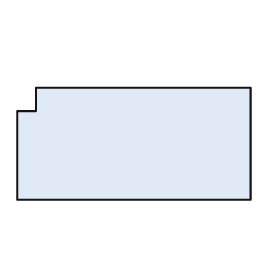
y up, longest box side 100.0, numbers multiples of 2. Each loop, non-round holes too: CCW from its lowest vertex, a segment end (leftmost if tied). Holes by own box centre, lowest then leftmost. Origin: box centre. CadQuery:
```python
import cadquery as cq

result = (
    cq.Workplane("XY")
    .moveTo(-50.0, -24.0)
    .lineTo(50.0, -24.0)
    .lineTo(50.0, 24.0)
    .lineTo(-42.0, 24.0)
    .lineTo(-42.0, 14.0)
    .lineTo(-50.0, 14.0)
    .close()
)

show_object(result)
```